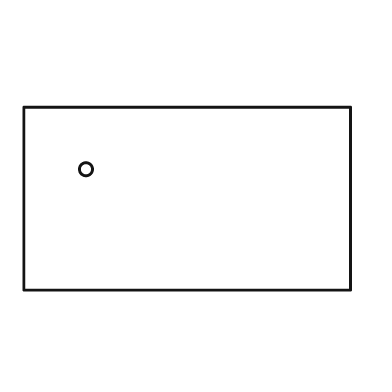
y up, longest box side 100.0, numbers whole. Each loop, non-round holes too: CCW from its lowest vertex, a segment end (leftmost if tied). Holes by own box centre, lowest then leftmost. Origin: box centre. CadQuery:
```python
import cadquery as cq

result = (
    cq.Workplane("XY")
    .moveTo(-50.0, -28.0)
    .lineTo(50.0, -28.0)
    .lineTo(50.0, 28.0)
    .lineTo(-50.0, 28.0)
    .close()
    .moveTo(-31.0, 9.0)
    .circle(2.0)
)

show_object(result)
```